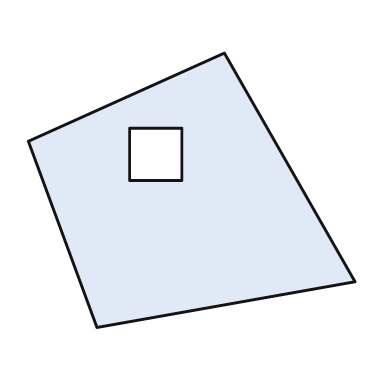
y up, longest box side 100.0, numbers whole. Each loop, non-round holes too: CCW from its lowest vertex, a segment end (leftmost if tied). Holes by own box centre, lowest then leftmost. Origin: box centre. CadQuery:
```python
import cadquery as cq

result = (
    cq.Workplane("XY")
    .moveTo(-29.0, -42.0)
    .lineTo(50.0, -28.0)
    .lineTo(10.0, 42.0)
    .lineTo(-50.0, 15.0)
    .close()
    .moveTo(-19.0, 3.0)
    .lineTo(-3.0, 3.0)
    .lineTo(-3.0, 19.0)
    .lineTo(-19.0, 19.0)
    .close()
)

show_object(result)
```